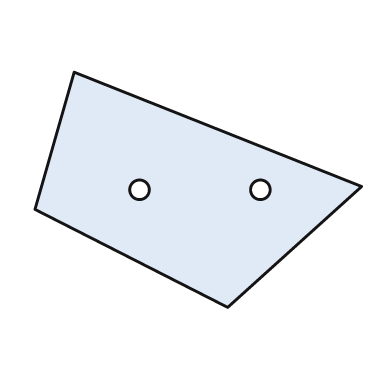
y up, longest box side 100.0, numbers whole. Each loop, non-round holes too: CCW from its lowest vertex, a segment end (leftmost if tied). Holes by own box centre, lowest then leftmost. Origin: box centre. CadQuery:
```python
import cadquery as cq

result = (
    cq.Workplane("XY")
    .moveTo(9.0, -36.0)
    .lineTo(50.0, 1.0)
    .lineTo(-38.0, 36.0)
    .lineTo(-50.0, -6.0)
    .close()
    .moveTo(-18.0, 0.0)
    .circle(3.0)
    .moveTo(19.0, 0.0)
    .circle(3.0)
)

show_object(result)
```